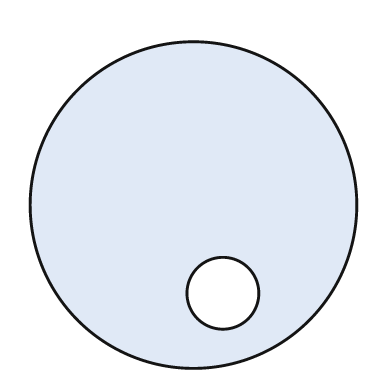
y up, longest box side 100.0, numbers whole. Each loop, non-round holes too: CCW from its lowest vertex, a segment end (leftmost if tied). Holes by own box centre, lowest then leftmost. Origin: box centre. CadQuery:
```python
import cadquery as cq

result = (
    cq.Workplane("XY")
    .moveTo(0.0, 0.0)
    .circle(50.0)
    .moveTo(9.0, -27.0)
    .circle(11.0)
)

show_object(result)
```